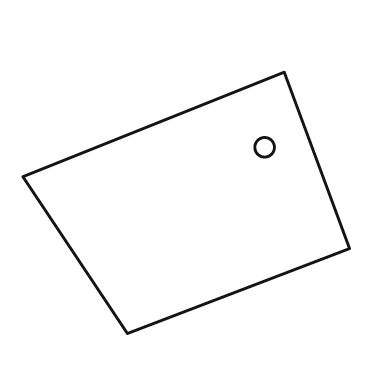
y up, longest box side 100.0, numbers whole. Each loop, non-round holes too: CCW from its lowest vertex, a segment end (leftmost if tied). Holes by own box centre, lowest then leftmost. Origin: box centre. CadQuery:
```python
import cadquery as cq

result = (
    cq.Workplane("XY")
    .moveTo(-18.0, -40.0)
    .lineTo(50.0, -14.0)
    .lineTo(30.0, 40.0)
    .lineTo(-50.0, 8.0)
    .close()
    .moveTo(24.0, 17.0)
    .circle(3.0)
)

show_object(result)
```